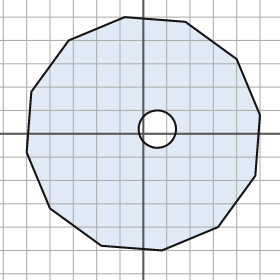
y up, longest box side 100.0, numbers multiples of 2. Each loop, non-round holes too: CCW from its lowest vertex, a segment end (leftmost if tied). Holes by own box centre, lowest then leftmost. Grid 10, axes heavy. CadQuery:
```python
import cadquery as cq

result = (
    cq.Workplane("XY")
    .moveTo(8.0, -50.0)
    .lineTo(32.0, -40.0)
    .lineTo(48.0, -18.0)
    .lineTo(50.0, 8.0)
    .lineTo(40.0, 32.0)
    .lineTo(18.0, 48.0)
    .lineTo(-8.0, 50.0)
    .lineTo(-32.0, 40.0)
    .lineTo(-48.0, 18.0)
    .lineTo(-50.0, -8.0)
    .lineTo(-40.0, -32.0)
    .lineTo(-18.0, -48.0)
    .close()
    .moveTo(6.0, 2.0)
    .circle(8.0)
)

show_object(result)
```